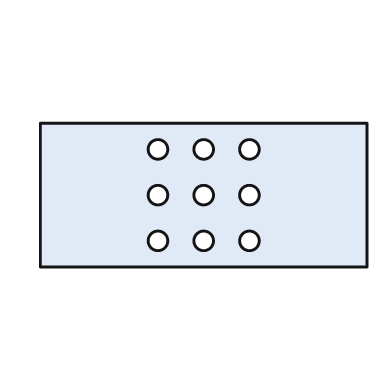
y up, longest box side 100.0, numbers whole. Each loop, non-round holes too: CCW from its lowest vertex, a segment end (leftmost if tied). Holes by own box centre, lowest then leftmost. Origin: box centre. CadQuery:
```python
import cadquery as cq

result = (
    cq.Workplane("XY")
    .moveTo(-50.0, -22.0)
    .lineTo(50.0, -22.0)
    .lineTo(50.0, 22.0)
    .lineTo(-50.0, 22.0)
    .close()
    .moveTo(-14.0, -14.0)
    .circle(3.0)
    .moveTo(0.0, -14.0)
    .circle(3.0)
    .moveTo(14.0, -14.0)
    .circle(3.0)
    .moveTo(-14.0, 0.0)
    .circle(3.0)
    .moveTo(0.0, 0.0)
    .circle(3.0)
    .moveTo(14.0, 0.0)
    .circle(3.0)
    .moveTo(-14.0, 14.0)
    .circle(3.0)
    .moveTo(0.0, 14.0)
    .circle(3.0)
    .moveTo(14.0, 14.0)
    .circle(3.0)
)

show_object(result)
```